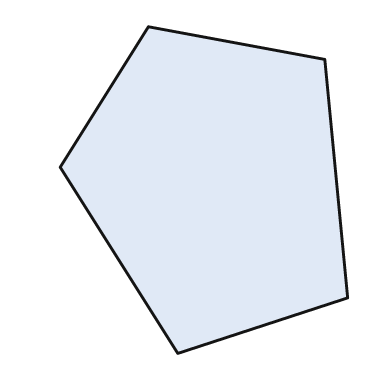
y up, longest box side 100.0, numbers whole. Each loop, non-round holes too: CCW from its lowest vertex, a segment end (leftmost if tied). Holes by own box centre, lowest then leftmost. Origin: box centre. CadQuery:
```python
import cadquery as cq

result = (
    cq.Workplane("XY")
    .moveTo(-8.0, -50.0)
    .lineTo(44.0, -33.0)
    .lineTo(37.0, 40.0)
    .lineTo(-17.0, 50.0)
    .lineTo(-44.0, 7.0)
    .close()
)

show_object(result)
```